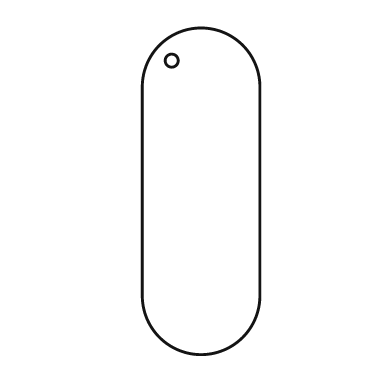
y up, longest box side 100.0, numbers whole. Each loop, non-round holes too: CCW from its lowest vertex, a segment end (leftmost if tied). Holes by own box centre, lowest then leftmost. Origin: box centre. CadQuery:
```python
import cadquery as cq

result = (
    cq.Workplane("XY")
    .moveTo(-18.0, -32.0)
    .threePointArc((0.0, -50.0), (18.0, -32.0))
    .lineTo(18.0, 32.0)
    .threePointArc((0.0, 50.0), (-18.0, 32.0))
    .close()
    .moveTo(-9.0, 40.0)
    .circle(2.0)
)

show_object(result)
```